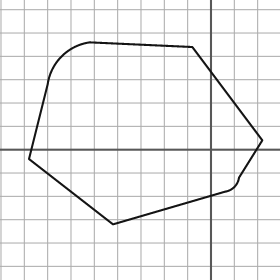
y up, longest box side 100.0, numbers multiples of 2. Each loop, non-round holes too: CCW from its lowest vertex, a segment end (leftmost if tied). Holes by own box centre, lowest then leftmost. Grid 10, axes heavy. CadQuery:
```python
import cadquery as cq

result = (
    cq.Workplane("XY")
    .moveTo(-42.0, -32.0)
    .lineTo(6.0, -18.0)
    .threePointArc((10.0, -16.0), (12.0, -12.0))
    .lineTo(22.0, 4.0)
    .lineTo(-8.0, 44.0)
    .lineTo(-52.0, 46.0)
    .threePointArc((-64.0, 40.0), (-70.0, 28.0))
    .lineTo(-78.0, -4.0)
    .close()
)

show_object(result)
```